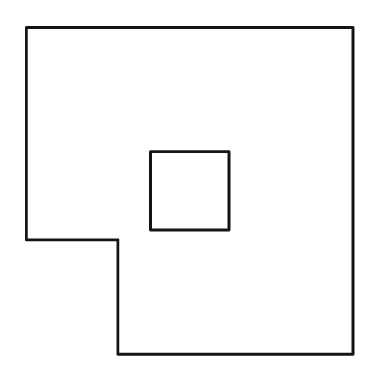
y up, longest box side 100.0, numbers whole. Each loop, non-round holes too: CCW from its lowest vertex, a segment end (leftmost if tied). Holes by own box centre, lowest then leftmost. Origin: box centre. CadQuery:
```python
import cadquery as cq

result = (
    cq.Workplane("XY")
    .moveTo(-22.0, -50.0)
    .lineTo(50.0, -50.0)
    .lineTo(50.0, 50.0)
    .lineTo(-50.0, 50.0)
    .lineTo(-50.0, -15.0)
    .lineTo(-22.0, -15.0)
    .close()
    .moveTo(-12.0, -12.0)
    .lineTo(12.0, -12.0)
    .lineTo(12.0, 12.0)
    .lineTo(-12.0, 12.0)
    .close()
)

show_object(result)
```